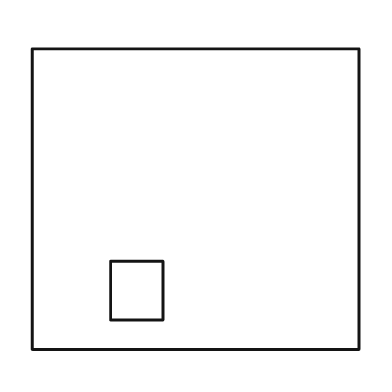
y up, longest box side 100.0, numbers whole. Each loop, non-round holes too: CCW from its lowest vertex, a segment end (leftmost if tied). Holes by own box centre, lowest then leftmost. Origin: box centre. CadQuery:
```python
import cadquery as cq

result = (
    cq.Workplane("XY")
    .moveTo(-50.0, -46.0)
    .lineTo(50.0, -46.0)
    .lineTo(50.0, 46.0)
    .lineTo(-50.0, 46.0)
    .close()
    .moveTo(-26.0, -37.0)
    .lineTo(-10.0, -37.0)
    .lineTo(-10.0, -19.0)
    .lineTo(-26.0, -19.0)
    .close()
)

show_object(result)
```